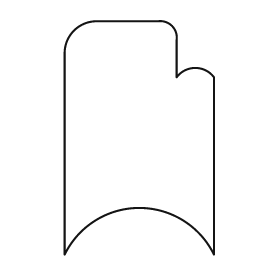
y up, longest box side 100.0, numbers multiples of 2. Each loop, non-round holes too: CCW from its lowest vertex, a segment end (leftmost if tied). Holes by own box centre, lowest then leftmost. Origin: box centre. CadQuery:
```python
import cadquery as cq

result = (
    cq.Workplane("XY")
    .moveTo(-32.0, -50.0)
    .threePointArc((0.0, -30.0), (32.0, -50.0))
    .lineTo(32.0, 26.0)
    .threePointArc((24.0, 30.0), (16.0, 26.0))
    .lineTo(16.0, 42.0)
    .threePointArc((14.0, 48.0), (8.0, 50.0))
    .lineTo(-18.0, 50.0)
    .threePointArc((-28.0, 46.0), (-32.0, 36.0))
    .close()
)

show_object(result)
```